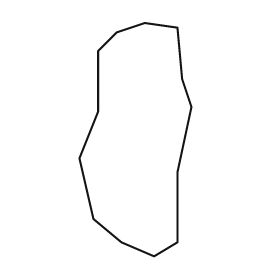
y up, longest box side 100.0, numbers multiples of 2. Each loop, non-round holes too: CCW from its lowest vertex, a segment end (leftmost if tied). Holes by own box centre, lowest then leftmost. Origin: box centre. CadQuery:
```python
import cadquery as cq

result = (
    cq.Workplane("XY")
    .moveTo(8.0, -50.0)
    .lineTo(18.0, -44.0)
    .lineTo(18.0, -14.0)
    .lineTo(24.0, 14.0)
    .lineTo(20.0, 26.0)
    .lineTo(18.0, 48.0)
    .lineTo(4.0, 50.0)
    .lineTo(-8.0, 46.0)
    .lineTo(-16.0, 38.0)
    .lineTo(-16.0, 12.0)
    .lineTo(-24.0, -8.0)
    .lineTo(-18.0, -34.0)
    .lineTo(-6.0, -44.0)
    .close()
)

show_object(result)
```